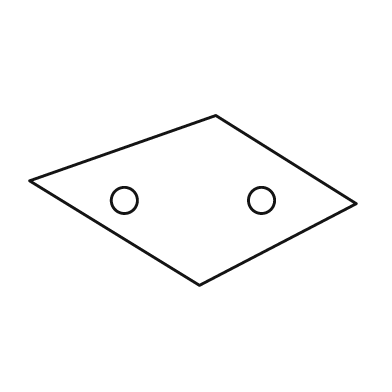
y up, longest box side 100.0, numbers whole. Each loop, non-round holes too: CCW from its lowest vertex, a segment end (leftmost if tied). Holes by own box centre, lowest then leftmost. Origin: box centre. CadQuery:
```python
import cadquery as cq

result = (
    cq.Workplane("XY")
    .moveTo(2.0, -26.0)
    .lineTo(50.0, -1.0)
    .lineTo(7.0, 26.0)
    .lineTo(-50.0, 6.0)
    .close()
    .moveTo(-21.0, 0.0)
    .circle(4.0)
    .moveTo(21.0, 0.0)
    .circle(4.0)
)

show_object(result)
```